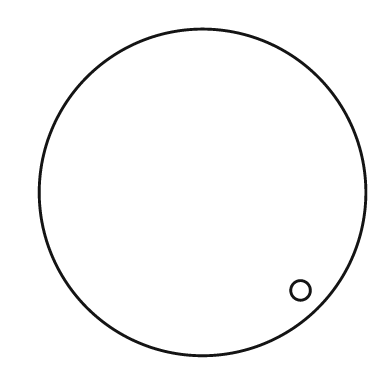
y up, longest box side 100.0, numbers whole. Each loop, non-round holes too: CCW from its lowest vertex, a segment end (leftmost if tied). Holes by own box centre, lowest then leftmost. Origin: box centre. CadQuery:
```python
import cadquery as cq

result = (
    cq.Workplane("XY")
    .moveTo(0.0, 0.0)
    .circle(50.0)
    .moveTo(30.0, -30.0)
    .circle(3.0)
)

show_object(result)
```